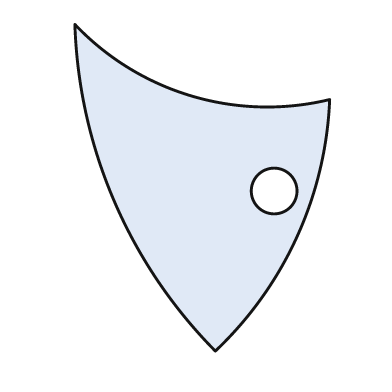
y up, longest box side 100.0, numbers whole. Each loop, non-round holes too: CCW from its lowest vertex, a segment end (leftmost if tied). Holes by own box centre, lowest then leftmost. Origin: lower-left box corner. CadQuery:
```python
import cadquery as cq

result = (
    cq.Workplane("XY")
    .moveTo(43.0, 0.0)
    .threePointArc((68.0, 35.0), (78.0, 77.0))
    .threePointArc((36.0, 78.0), (0.0, 100.0))
    .threePointArc((12.0, 46.0), (43.0, 0.0))
    .close()
    .moveTo(61.0, 49.0)
    .circle(7.0)
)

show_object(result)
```